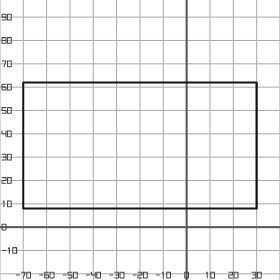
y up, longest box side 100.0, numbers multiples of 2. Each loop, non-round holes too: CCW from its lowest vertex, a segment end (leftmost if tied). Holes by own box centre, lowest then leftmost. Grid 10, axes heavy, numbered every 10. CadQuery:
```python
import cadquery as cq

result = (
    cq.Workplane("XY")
    .moveTo(-70.0, 8.0)
    .lineTo(30.0, 8.0)
    .lineTo(30.0, 62.0)
    .lineTo(-70.0, 62.0)
    .close()
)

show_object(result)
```